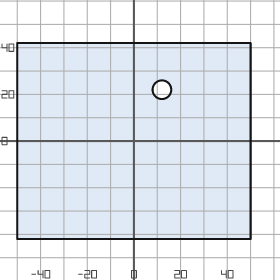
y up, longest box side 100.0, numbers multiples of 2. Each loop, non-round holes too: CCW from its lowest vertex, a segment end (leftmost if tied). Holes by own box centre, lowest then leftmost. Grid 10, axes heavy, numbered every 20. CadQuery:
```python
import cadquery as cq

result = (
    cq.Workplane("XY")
    .moveTo(-50.0, -42.0)
    .lineTo(50.0, -42.0)
    .lineTo(50.0, 42.0)
    .lineTo(-50.0, 42.0)
    .close()
    .moveTo(12.0, 22.0)
    .circle(4.0)
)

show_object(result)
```